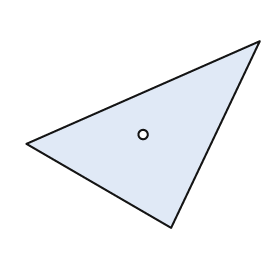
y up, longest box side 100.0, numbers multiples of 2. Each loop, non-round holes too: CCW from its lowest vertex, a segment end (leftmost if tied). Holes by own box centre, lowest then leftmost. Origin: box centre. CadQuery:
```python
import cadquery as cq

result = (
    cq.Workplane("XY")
    .moveTo(12.0, -40.0)
    .lineTo(50.0, 40.0)
    .lineTo(-50.0, -4.0)
    .close()
    .moveTo(0.0, 0.0)
    .circle(2.0)
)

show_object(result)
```